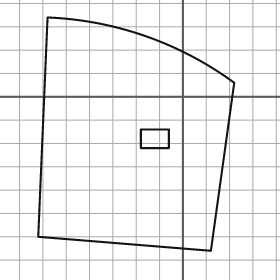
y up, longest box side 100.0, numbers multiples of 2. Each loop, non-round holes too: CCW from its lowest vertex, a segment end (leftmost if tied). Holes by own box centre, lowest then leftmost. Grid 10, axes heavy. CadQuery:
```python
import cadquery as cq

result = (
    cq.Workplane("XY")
    .moveTo(12.0, -66.0)
    .lineTo(22.0, 6.0)
    .threePointArc((-16.0, 26.0), (-58.0, 34.0))
    .lineTo(-62.0, -60.0)
    .close()
    .moveTo(-18.0, -22.0)
    .lineTo(-6.0, -22.0)
    .lineTo(-6.0, -14.0)
    .lineTo(-18.0, -14.0)
    .close()
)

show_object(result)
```